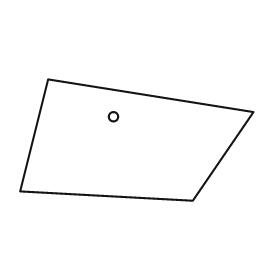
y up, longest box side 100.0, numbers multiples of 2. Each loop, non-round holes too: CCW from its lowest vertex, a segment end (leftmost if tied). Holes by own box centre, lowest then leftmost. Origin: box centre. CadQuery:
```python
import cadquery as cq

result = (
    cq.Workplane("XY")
    .moveTo(24.0, -26.0)
    .lineTo(50.0, 12.0)
    .lineTo(-38.0, 26.0)
    .lineTo(-50.0, -22.0)
    .close()
    .moveTo(-10.0, 10.0)
    .circle(2.0)
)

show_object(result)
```